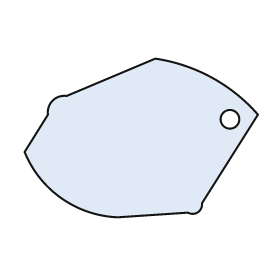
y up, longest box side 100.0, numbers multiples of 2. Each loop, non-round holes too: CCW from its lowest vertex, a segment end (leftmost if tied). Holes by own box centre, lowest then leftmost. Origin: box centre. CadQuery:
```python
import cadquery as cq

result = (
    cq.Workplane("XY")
    .moveTo(-10.0, -34.0)
    .lineTo(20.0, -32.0)
    .threePointArc((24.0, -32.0), (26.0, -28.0))
    .lineTo(50.0, 10.0)
    .threePointArc((30.0, 26.0), (6.0, 34.0))
    .lineTo(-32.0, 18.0)
    .threePointArc((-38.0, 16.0), (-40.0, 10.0))
    .lineTo(-50.0, -6.0)
    .threePointArc((-34.0, -26.0), (-10.0, -34.0))
    .close()
    .moveTo(38.0, 8.0)
    .circle(4.0)
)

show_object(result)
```